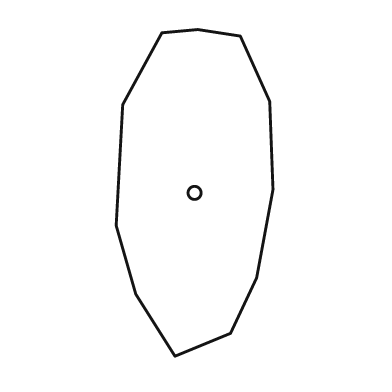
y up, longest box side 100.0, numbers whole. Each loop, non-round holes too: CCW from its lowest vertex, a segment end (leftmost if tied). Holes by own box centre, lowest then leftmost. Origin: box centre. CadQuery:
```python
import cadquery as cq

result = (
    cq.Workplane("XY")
    .moveTo(-6.0, -50.0)
    .lineTo(11.0, -43.0)
    .lineTo(19.0, -26.0)
    .lineTo(24.0, 1.0)
    .lineTo(23.0, 28.0)
    .lineTo(14.0, 48.0)
    .lineTo(1.0, 50.0)
    .lineTo(-10.0, 49.0)
    .lineTo(-22.0, 27.0)
    .lineTo(-24.0, -10.0)
    .lineTo(-18.0, -31.0)
    .close()
    .moveTo(0.0, 0.0)
    .circle(2.0)
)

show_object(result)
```